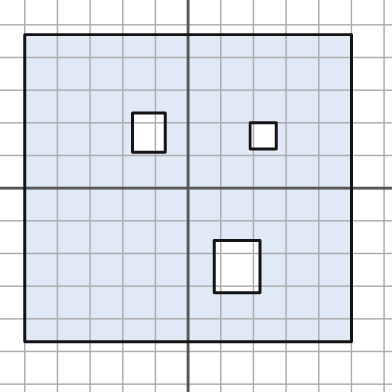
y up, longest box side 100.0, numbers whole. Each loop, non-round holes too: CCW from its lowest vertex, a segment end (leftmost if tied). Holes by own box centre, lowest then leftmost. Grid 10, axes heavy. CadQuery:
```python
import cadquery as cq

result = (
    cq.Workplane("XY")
    .moveTo(-50.0, -47.0)
    .lineTo(50.0, -47.0)
    .lineTo(50.0, 47.0)
    .lineTo(-50.0, 47.0)
    .close()
    .moveTo(8.0, -32.0)
    .lineTo(22.0, -32.0)
    .lineTo(22.0, -16.0)
    .lineTo(8.0, -16.0)
    .close()
    .moveTo(19.0, 12.0)
    .lineTo(27.0, 12.0)
    .lineTo(27.0, 20.0)
    .lineTo(19.0, 20.0)
    .close()
    .moveTo(-17.0, 11.0)
    .lineTo(-7.0, 11.0)
    .lineTo(-7.0, 23.0)
    .lineTo(-17.0, 23.0)
    .close()
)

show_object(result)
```